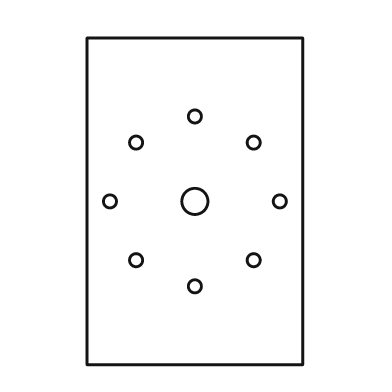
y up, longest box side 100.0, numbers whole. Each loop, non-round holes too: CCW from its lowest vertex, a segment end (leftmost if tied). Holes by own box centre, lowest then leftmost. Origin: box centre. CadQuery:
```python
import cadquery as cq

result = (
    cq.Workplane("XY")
    .moveTo(-33.0, -50.0)
    .lineTo(33.0, -50.0)
    .lineTo(33.0, 50.0)
    .lineTo(-33.0, 50.0)
    .close()
    .moveTo(0.0, -26.0)
    .circle(2.0)
    .moveTo(-18.0, -18.0)
    .circle(2.0)
    .moveTo(18.0, -18.0)
    .circle(2.0)
    .moveTo(-26.0, 0.0)
    .circle(2.0)
    .moveTo(0.0, 0.0)
    .circle(4.0)
    .moveTo(26.0, 0.0)
    .circle(2.0)
    .moveTo(-18.0, 18.0)
    .circle(2.0)
    .moveTo(18.0, 18.0)
    .circle(2.0)
    .moveTo(0.0, 26.0)
    .circle(2.0)
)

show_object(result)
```